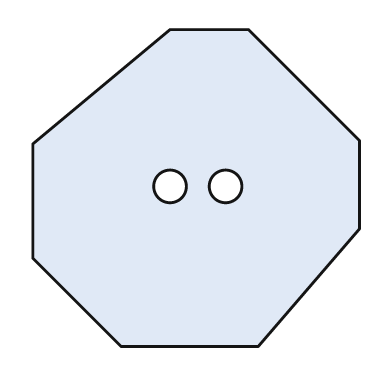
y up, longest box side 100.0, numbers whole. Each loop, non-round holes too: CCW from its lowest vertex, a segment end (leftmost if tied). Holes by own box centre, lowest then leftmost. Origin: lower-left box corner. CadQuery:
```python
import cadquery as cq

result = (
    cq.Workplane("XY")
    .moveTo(27.0, 0.0)
    .lineTo(69.0, 0.0)
    .lineTo(100.0, 36.0)
    .lineTo(100.0, 63.0)
    .lineTo(66.0, 97.0)
    .lineTo(42.0, 97.0)
    .lineTo(0.0, 62.0)
    .lineTo(0.0, 27.0)
    .close()
    .moveTo(42.0, 49.0)
    .circle(5.0)
    .moveTo(59.0, 49.0)
    .circle(5.0)
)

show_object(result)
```